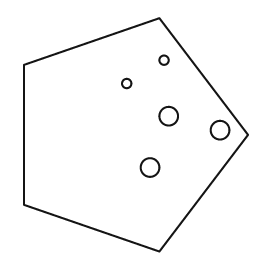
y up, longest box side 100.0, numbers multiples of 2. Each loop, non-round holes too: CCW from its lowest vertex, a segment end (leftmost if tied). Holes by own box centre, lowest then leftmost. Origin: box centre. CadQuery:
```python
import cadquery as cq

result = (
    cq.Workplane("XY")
    .moveTo(10.0, -50.0)
    .lineTo(48.0, 0.0)
    .lineTo(10.0, 50.0)
    .lineTo(-48.0, 30.0)
    .lineTo(-48.0, -30.0)
    .close()
    .moveTo(6.0, -14.0)
    .circle(4.0)
    .moveTo(36.0, 2.0)
    .circle(4.0)
    .moveTo(14.0, 8.0)
    .circle(4.0)
    .moveTo(-4.0, 22.0)
    .circle(2.0)
    .moveTo(12.0, 32.0)
    .circle(2.0)
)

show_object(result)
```